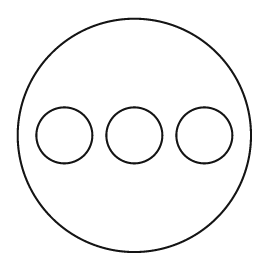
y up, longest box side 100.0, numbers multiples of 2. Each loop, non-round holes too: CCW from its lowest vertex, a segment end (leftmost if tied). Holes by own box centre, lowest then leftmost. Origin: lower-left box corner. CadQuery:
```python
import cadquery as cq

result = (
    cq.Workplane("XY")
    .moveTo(50.0, 50.0)
    .circle(50.0)
    .moveTo(20.0, 50.0)
    .circle(12.0)
    .moveTo(50.0, 50.0)
    .circle(12.0)
    .moveTo(80.0, 50.0)
    .circle(12.0)
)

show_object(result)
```